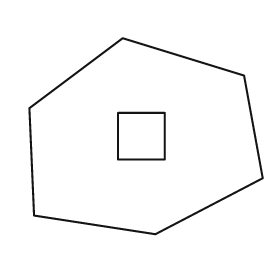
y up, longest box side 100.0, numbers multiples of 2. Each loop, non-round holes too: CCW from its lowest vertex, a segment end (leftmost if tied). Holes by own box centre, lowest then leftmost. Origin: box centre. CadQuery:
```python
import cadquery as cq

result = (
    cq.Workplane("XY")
    .moveTo(4.0, -42.0)
    .lineTo(50.0, -18.0)
    .lineTo(42.0, 26.0)
    .lineTo(-10.0, 42.0)
    .lineTo(-50.0, 12.0)
    .lineTo(-48.0, -34.0)
    .close()
    .moveTo(-12.0, -10.0)
    .lineTo(8.0, -10.0)
    .lineTo(8.0, 10.0)
    .lineTo(-12.0, 10.0)
    .close()
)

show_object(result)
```